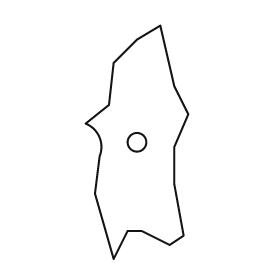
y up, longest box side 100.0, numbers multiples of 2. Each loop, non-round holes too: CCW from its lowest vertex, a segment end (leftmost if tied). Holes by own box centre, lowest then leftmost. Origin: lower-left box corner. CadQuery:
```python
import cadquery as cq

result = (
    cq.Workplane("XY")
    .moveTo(12.0, 0.0)
    .lineTo(18.0, 12.0)
    .lineTo(24.0, 12.0)
    .lineTo(36.0, 6.0)
    .lineTo(42.0, 10.0)
    .lineTo(38.0, 32.0)
    .lineTo(38.0, 48.0)
    .lineTo(44.0, 62.0)
    .lineTo(38.0, 74.0)
    .lineTo(32.0, 100.0)
    .lineTo(22.0, 94.0)
    .lineTo(12.0, 84.0)
    .lineTo(10.0, 66.0)
    .lineTo(0.0, 58.0)
    .threePointArc((6.0, 52.0), (6.0, 44.0))
    .lineTo(4.0, 28.0)
    .close()
    .moveTo(22.0, 50.0)
    .circle(4.0)
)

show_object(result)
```